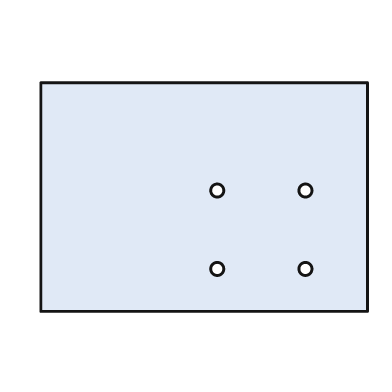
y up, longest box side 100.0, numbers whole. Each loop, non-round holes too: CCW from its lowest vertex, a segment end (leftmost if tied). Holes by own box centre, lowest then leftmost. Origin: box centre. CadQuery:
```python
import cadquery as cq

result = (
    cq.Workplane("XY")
    .moveTo(-50.0, -35.0)
    .lineTo(50.0, -35.0)
    .lineTo(50.0, 35.0)
    .lineTo(-50.0, 35.0)
    .close()
    .moveTo(4.0, -22.0)
    .circle(2.0)
    .moveTo(31.0, -22.0)
    .circle(2.0)
    .moveTo(4.0, 2.0)
    .circle(2.0)
    .moveTo(31.0, 2.0)
    .circle(2.0)
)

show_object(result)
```